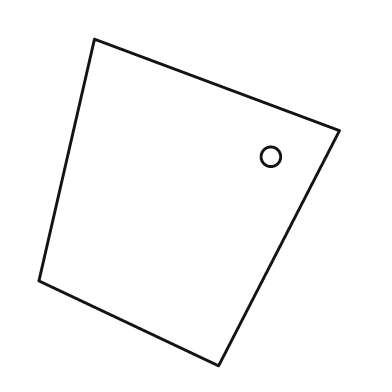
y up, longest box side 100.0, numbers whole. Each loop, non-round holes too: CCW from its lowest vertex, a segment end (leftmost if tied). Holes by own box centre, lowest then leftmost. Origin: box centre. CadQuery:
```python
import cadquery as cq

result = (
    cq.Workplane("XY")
    .moveTo(9.0, -50.0)
    .lineTo(46.0, 22.0)
    .lineTo(-29.0, 50.0)
    .lineTo(-46.0, -24.0)
    .close()
    .moveTo(25.0, 14.0)
    .circle(3.0)
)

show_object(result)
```